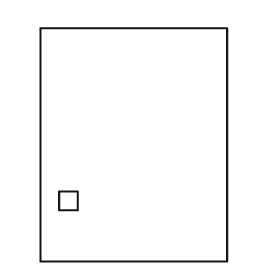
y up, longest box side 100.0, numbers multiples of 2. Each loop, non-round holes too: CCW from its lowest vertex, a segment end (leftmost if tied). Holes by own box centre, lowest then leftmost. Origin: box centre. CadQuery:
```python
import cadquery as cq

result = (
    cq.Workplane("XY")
    .moveTo(-40.0, -50.0)
    .lineTo(40.0, -50.0)
    .lineTo(40.0, 50.0)
    .lineTo(-40.0, 50.0)
    .close()
    .moveTo(-32.0, -28.0)
    .lineTo(-24.0, -28.0)
    .lineTo(-24.0, -20.0)
    .lineTo(-32.0, -20.0)
    .close()
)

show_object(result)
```